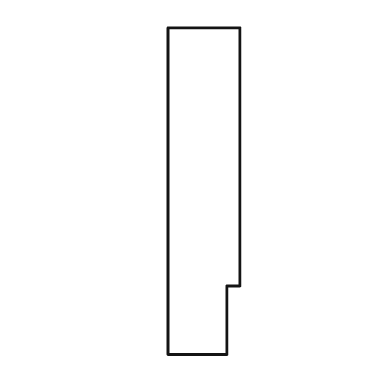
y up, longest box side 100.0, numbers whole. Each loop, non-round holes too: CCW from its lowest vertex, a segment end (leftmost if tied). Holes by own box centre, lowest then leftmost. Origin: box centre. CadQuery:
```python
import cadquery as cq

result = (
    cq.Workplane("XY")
    .moveTo(-11.0, -50.0)
    .lineTo(7.0, -50.0)
    .lineTo(7.0, -29.0)
    .lineTo(11.0, -29.0)
    .lineTo(11.0, 50.0)
    .lineTo(-11.0, 50.0)
    .close()
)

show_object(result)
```